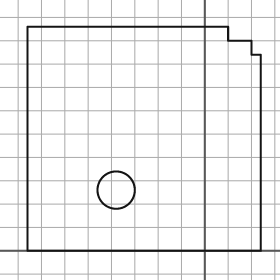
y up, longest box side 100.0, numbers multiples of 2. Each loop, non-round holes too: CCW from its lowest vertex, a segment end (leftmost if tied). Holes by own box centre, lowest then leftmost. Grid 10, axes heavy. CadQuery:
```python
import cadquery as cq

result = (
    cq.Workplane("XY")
    .moveTo(-76.0, 0.0)
    .lineTo(24.0, 0.0)
    .lineTo(24.0, 84.0)
    .lineTo(20.0, 84.0)
    .lineTo(20.0, 90.0)
    .lineTo(10.0, 90.0)
    .lineTo(10.0, 96.0)
    .lineTo(-76.0, 96.0)
    .close()
    .moveTo(-38.0, 26.0)
    .circle(8.0)
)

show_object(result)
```